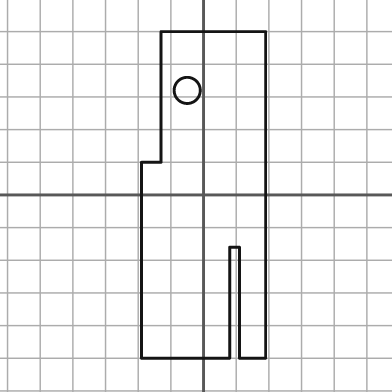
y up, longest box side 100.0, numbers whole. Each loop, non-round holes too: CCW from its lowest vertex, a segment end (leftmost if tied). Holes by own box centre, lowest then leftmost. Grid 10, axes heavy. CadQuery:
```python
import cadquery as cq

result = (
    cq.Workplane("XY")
    .moveTo(-19.0, -50.0)
    .lineTo(8.0, -50.0)
    .lineTo(8.0, -16.0)
    .lineTo(11.0, -16.0)
    .lineTo(11.0, -50.0)
    .lineTo(19.0, -50.0)
    .lineTo(19.0, 50.0)
    .lineTo(-13.0, 50.0)
    .lineTo(-13.0, 10.0)
    .lineTo(-19.0, 10.0)
    .close()
    .moveTo(-5.0, 32.0)
    .circle(4.0)
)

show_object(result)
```